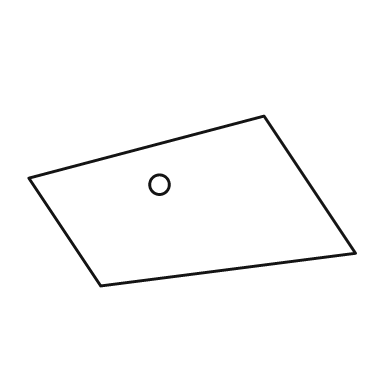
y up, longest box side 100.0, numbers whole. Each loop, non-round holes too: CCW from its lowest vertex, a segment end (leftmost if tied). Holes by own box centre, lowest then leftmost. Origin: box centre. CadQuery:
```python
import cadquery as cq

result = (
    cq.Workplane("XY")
    .moveTo(-28.0, -26.0)
    .lineTo(50.0, -16.0)
    .lineTo(22.0, 26.0)
    .lineTo(-50.0, 7.0)
    .close()
    .moveTo(-10.0, 5.0)
    .circle(3.0)
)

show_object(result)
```